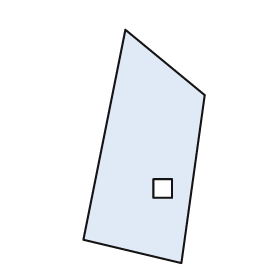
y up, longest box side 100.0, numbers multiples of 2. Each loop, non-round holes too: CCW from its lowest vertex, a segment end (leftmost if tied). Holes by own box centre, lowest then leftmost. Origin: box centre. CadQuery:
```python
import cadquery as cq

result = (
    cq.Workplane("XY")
    .moveTo(16.0, -50.0)
    .lineTo(26.0, 22.0)
    .lineTo(-8.0, 50.0)
    .lineTo(-26.0, -40.0)
    .close()
    .moveTo(4.0, -22.0)
    .lineTo(12.0, -22.0)
    .lineTo(12.0, -14.0)
    .lineTo(4.0, -14.0)
    .close()
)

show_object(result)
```